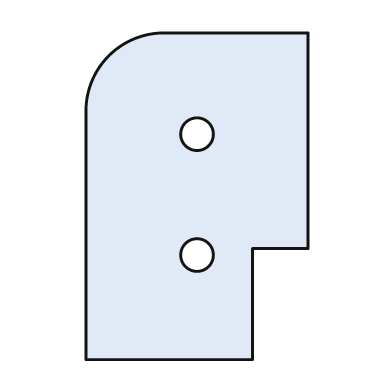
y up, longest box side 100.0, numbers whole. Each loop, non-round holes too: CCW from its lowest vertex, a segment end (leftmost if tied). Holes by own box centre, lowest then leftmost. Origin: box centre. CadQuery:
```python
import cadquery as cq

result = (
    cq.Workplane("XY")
    .moveTo(-34.0, -50.0)
    .lineTo(17.0, -50.0)
    .lineTo(17.0, -16.0)
    .lineTo(34.0, -16.0)
    .lineTo(34.0, 50.0)
    .lineTo(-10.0, 50.0)
    .threePointArc((-27.0, 43.0), (-34.0, 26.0))
    .close()
    .moveTo(0.0, -18.0)
    .circle(5.0)
    .moveTo(0.0, 19.0)
    .circle(5.0)
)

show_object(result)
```